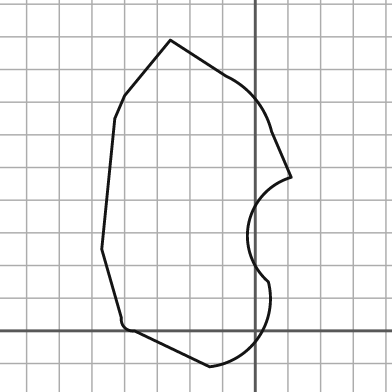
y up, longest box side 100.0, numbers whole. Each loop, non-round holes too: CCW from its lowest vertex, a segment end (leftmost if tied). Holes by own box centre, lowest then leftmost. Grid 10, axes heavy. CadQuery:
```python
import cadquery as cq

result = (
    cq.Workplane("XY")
    .moveTo(-14.0, -11.0)
    .threePointArc((1.0, -2.0), (4.0, 15.0))
    .threePointArc((-2.0, 33.0), (11.0, 47.0))
    .lineTo(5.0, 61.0)
    .threePointArc((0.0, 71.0), (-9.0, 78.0))
    .lineTo(-26.0, 89.0)
    .lineTo(-40.0, 72.0)
    .lineTo(-43.0, 65.0)
    .lineTo(-47.0, 25.0)
    .lineTo(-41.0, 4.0)
    .threePointArc((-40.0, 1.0), (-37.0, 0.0))
    .close()
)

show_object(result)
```